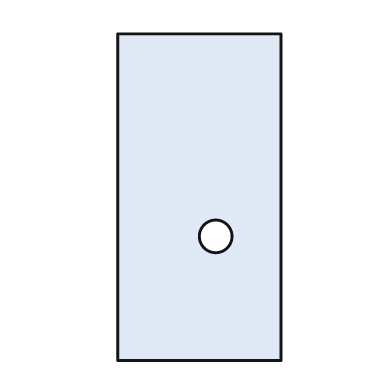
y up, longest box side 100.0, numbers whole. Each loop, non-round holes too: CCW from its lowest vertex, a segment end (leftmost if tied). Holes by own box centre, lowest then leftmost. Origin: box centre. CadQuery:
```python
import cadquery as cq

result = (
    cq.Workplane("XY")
    .moveTo(-25.0, -50.0)
    .lineTo(25.0, -50.0)
    .lineTo(25.0, 50.0)
    .lineTo(-25.0, 50.0)
    .close()
    .moveTo(5.0, -12.0)
    .circle(5.0)
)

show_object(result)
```